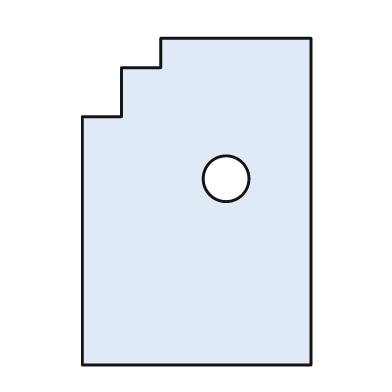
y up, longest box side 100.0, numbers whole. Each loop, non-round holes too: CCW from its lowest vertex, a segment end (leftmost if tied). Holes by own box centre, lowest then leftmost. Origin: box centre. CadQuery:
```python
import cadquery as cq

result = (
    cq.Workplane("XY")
    .moveTo(-35.0, -50.0)
    .lineTo(35.0, -50.0)
    .lineTo(35.0, 50.0)
    .lineTo(-11.0, 50.0)
    .lineTo(-11.0, 41.0)
    .lineTo(-23.0, 41.0)
    .lineTo(-23.0, 26.0)
    .lineTo(-35.0, 26.0)
    .close()
    .moveTo(9.0, 7.0)
    .circle(7.0)
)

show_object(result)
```